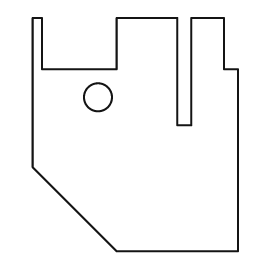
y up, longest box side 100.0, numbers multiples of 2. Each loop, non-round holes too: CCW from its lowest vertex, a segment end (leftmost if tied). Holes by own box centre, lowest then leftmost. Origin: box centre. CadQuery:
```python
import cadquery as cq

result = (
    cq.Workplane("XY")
    .moveTo(-8.0, -50.0)
    .lineTo(44.0, -50.0)
    .lineTo(44.0, 28.0)
    .lineTo(38.0, 28.0)
    .lineTo(38.0, 50.0)
    .lineTo(24.0, 50.0)
    .lineTo(24.0, 4.0)
    .lineTo(18.0, 4.0)
    .lineTo(18.0, 50.0)
    .lineTo(-8.0, 50.0)
    .lineTo(-8.0, 28.0)
    .lineTo(-40.0, 28.0)
    .lineTo(-40.0, 50.0)
    .lineTo(-44.0, 50.0)
    .lineTo(-44.0, -14.0)
    .close()
    .moveTo(-16.0, 16.0)
    .circle(6.0)
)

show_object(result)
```